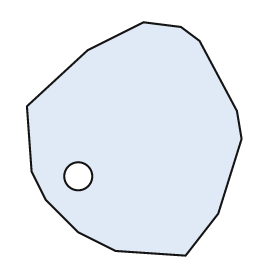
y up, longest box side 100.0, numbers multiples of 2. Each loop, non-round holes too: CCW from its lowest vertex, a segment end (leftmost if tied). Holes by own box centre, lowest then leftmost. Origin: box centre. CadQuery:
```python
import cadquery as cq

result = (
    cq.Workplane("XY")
    .moveTo(22.0, -50.0)
    .lineTo(36.0, -32.0)
    .lineTo(46.0, 0.0)
    .lineTo(44.0, 12.0)
    .lineTo(28.0, 42.0)
    .lineTo(20.0, 48.0)
    .lineTo(4.0, 50.0)
    .lineTo(-20.0, 38.0)
    .lineTo(-46.0, 14.0)
    .lineTo(-44.0, -14.0)
    .lineTo(-38.0, -26.0)
    .lineTo(-24.0, -40.0)
    .lineTo(-8.0, -48.0)
    .close()
    .moveTo(-24.0, -16.0)
    .circle(6.0)
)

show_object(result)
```